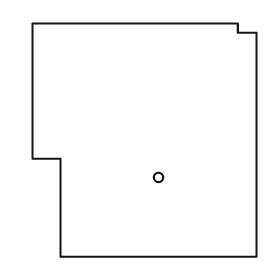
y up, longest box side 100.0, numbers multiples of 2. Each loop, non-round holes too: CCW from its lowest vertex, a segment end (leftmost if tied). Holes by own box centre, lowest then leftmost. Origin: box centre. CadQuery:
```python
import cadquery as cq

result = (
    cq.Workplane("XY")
    .moveTo(-36.0, -50.0)
    .lineTo(48.0, -50.0)
    .lineTo(48.0, 46.0)
    .lineTo(40.0, 46.0)
    .lineTo(40.0, 50.0)
    .lineTo(-48.0, 50.0)
    .lineTo(-48.0, -8.0)
    .lineTo(-36.0, -8.0)
    .close()
    .moveTo(6.0, -16.0)
    .circle(2.0)
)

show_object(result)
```